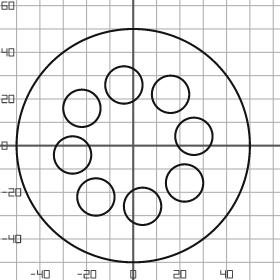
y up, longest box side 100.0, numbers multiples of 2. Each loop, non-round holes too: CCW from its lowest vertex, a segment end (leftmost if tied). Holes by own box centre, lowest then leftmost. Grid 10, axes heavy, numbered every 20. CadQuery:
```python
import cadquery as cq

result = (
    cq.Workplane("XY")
    .moveTo(0.0, 0.0)
    .circle(50.0)
    .moveTo(4.0, -26.0)
    .circle(8.0)
    .moveTo(-16.0, -22.0)
    .circle(8.0)
    .moveTo(22.0, -16.0)
    .circle(8.0)
    .moveTo(-26.0, -4.0)
    .circle(8.0)
    .moveTo(26.0, 4.0)
    .circle(8.0)
    .moveTo(-22.0, 16.0)
    .circle(8.0)
    .moveTo(16.0, 22.0)
    .circle(8.0)
    .moveTo(-4.0, 26.0)
    .circle(8.0)
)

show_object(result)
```